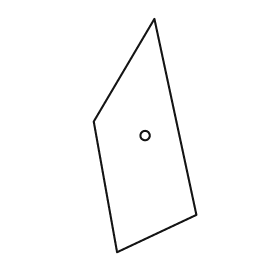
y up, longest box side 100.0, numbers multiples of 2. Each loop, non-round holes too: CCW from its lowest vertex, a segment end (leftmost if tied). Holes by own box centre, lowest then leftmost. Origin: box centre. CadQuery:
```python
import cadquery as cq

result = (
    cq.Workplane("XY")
    .moveTo(-12.0, -50.0)
    .lineTo(22.0, -34.0)
    .lineTo(4.0, 50.0)
    .lineTo(-22.0, 6.0)
    .close()
    .moveTo(0.0, 0.0)
    .circle(2.0)
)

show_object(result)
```